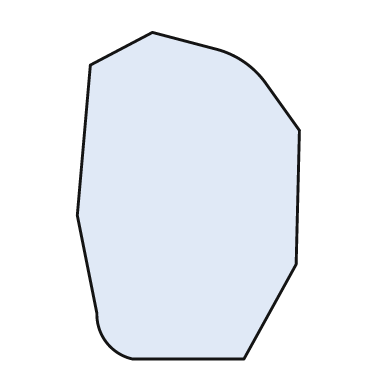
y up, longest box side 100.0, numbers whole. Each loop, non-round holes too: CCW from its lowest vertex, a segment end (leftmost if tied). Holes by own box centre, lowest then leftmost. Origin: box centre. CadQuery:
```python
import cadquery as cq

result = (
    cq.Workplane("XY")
    .moveTo(-17.0, -50.0)
    .lineTo(17.0, -50.0)
    .lineTo(33.0, -21.0)
    .lineTo(34.0, 20.0)
    .lineTo(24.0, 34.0)
    .threePointArc((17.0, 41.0), (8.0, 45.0))
    .lineTo(-11.0, 50.0)
    .lineTo(-30.0, 40.0)
    .lineTo(-34.0, -6.0)
    .lineTo(-28.0, -36.0)
    .threePointArc((-25.0, -45.0), (-17.0, -50.0))
    .close()
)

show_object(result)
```